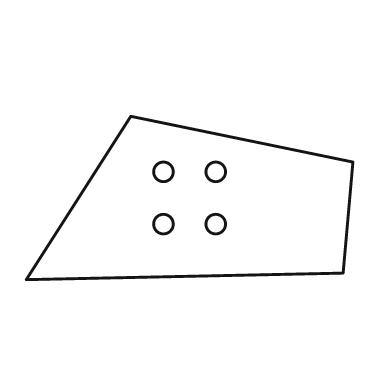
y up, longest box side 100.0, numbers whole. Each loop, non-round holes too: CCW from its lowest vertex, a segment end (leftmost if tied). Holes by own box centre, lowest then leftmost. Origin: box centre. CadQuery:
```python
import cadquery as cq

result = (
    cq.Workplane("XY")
    .moveTo(-50.0, -25.0)
    .lineTo(47.0, -23.0)
    .lineTo(50.0, 11.0)
    .lineTo(-18.0, 25.0)
    .close()
    .moveTo(-8.0, -8.0)
    .circle(3.0)
    .moveTo(8.0, -8.0)
    .circle(3.0)
    .moveTo(-8.0, 8.0)
    .circle(3.0)
    .moveTo(8.0, 8.0)
    .circle(3.0)
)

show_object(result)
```